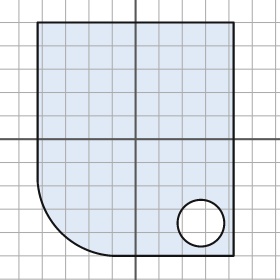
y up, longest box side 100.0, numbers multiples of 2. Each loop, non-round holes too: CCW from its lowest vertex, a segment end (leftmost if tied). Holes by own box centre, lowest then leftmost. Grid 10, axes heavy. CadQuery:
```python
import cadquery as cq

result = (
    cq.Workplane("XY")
    .moveTo(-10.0, -50.0)
    .lineTo(42.0, -50.0)
    .lineTo(42.0, 50.0)
    .lineTo(-42.0, 50.0)
    .lineTo(-42.0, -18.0)
    .threePointArc((-32.0, -40.0), (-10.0, -50.0))
    .close()
    .moveTo(28.0, -36.0)
    .circle(10.0)
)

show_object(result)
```